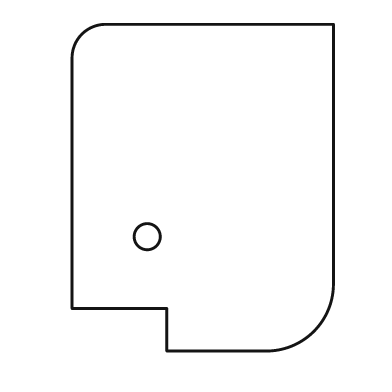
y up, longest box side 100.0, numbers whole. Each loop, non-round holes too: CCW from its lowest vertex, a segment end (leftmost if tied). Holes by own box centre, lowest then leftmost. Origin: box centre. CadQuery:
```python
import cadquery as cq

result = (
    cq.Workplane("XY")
    .moveTo(-11.0, -50.0)
    .lineTo(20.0, -50.0)
    .threePointArc((34.0, -44.0), (40.0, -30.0))
    .lineTo(40.0, 50.0)
    .lineTo(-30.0, 50.0)
    .threePointArc((-37.0, 47.0), (-40.0, 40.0))
    .lineTo(-40.0, -37.0)
    .lineTo(-11.0, -37.0)
    .close()
    .moveTo(-17.0, -15.0)
    .circle(4.0)
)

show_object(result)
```